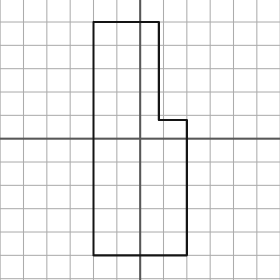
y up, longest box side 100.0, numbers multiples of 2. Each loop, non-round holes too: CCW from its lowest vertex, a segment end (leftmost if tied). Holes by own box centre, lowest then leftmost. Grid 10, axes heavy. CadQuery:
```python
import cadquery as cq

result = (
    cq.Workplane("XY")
    .moveTo(-20.0, -50.0)
    .lineTo(20.0, -50.0)
    .lineTo(20.0, 8.0)
    .lineTo(8.0, 8.0)
    .lineTo(8.0, 50.0)
    .lineTo(-20.0, 50.0)
    .close()
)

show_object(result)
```